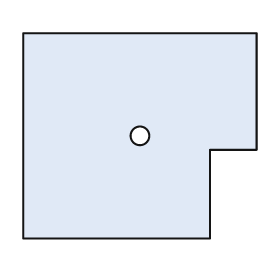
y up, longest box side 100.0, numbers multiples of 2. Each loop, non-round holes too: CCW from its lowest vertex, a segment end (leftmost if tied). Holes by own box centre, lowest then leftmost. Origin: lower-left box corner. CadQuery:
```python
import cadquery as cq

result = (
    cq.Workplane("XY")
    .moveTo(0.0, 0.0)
    .lineTo(80.0, 0.0)
    .lineTo(80.0, 38.0)
    .lineTo(100.0, 38.0)
    .lineTo(100.0, 88.0)
    .lineTo(0.0, 88.0)
    .close()
    .moveTo(50.0, 44.0)
    .circle(4.0)
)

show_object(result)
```